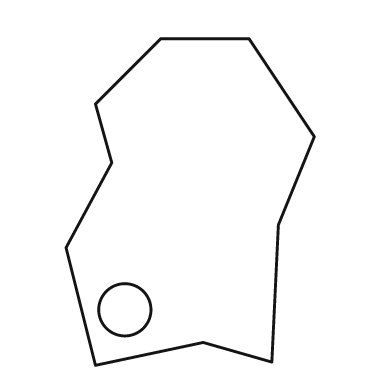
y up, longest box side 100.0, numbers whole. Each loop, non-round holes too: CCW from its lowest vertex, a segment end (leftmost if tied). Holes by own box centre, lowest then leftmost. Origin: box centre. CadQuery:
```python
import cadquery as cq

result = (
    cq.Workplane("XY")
    .moveTo(-29.0, -50.0)
    .lineTo(4.0, -43.0)
    .lineTo(25.0, -49.0)
    .lineTo(27.0, -7.0)
    .lineTo(38.0, 20.0)
    .lineTo(18.0, 50.0)
    .lineTo(-9.0, 50.0)
    .lineTo(-29.0, 30.0)
    .lineTo(-24.0, 12.0)
    .lineTo(-38.0, -14.0)
    .close()
    .moveTo(-20.0, -33.0)
    .circle(8.0)
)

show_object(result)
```